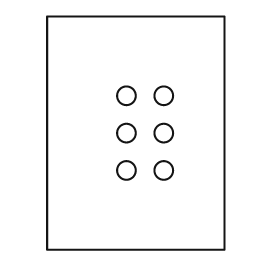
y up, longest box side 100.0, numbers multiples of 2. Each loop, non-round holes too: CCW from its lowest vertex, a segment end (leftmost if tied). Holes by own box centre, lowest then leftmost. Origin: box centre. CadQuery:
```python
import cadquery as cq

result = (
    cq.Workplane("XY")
    .moveTo(-38.0, -50.0)
    .lineTo(38.0, -50.0)
    .lineTo(38.0, 50.0)
    .lineTo(-38.0, 50.0)
    .close()
    .moveTo(-4.0, -16.0)
    .circle(4.0)
    .moveTo(12.0, -16.0)
    .circle(4.0)
    .moveTo(-4.0, 0.0)
    .circle(4.0)
    .moveTo(12.0, 0.0)
    .circle(4.0)
    .moveTo(-4.0, 16.0)
    .circle(4.0)
    .moveTo(12.0, 16.0)
    .circle(4.0)
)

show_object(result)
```